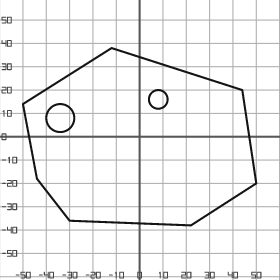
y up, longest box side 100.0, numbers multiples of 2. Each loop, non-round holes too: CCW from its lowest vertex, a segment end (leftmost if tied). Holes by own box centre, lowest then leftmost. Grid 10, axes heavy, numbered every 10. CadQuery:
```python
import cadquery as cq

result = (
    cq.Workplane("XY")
    .moveTo(22.0, -38.0)
    .lineTo(50.0, -20.0)
    .lineTo(44.0, 20.0)
    .lineTo(-12.0, 38.0)
    .lineTo(-50.0, 14.0)
    .lineTo(-44.0, -18.0)
    .lineTo(-30.0, -36.0)
    .close()
    .moveTo(-34.0, 8.0)
    .circle(6.0)
    .moveTo(8.0, 16.0)
    .circle(4.0)
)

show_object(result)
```